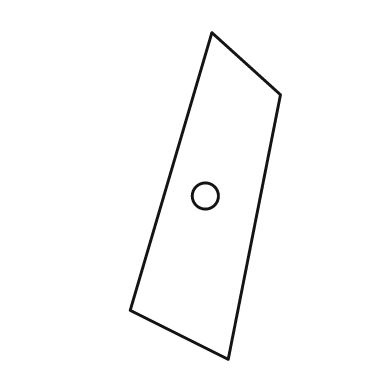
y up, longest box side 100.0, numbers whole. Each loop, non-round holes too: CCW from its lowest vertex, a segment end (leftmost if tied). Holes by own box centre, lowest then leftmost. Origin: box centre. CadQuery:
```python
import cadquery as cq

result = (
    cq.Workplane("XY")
    .moveTo(7.0, -50.0)
    .lineTo(23.0, 31.0)
    .lineTo(2.0, 50.0)
    .lineTo(-23.0, -35.0)
    .close()
    .moveTo(0.0, 0.0)
    .circle(4.0)
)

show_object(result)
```